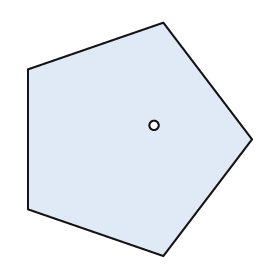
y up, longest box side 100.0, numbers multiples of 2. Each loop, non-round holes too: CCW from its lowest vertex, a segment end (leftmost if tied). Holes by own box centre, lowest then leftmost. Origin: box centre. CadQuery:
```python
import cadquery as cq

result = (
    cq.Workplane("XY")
    .moveTo(10.0, -50.0)
    .lineTo(48.0, 0.0)
    .lineTo(10.0, 50.0)
    .lineTo(-48.0, 30.0)
    .lineTo(-48.0, -30.0)
    .close()
    .moveTo(6.0, 6.0)
    .circle(2.0)
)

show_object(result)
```